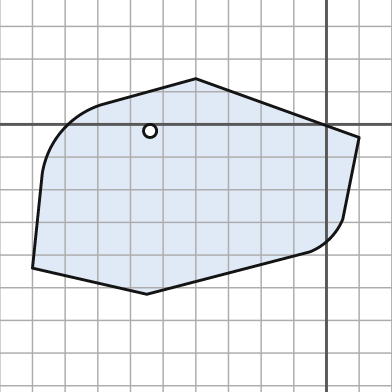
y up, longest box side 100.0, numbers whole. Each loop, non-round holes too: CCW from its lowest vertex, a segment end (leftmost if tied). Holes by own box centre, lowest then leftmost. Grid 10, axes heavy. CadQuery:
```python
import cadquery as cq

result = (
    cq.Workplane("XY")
    .moveTo(-55.0, -52.0)
    .lineTo(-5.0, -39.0)
    .threePointArc((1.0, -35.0), (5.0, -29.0))
    .lineTo(10.0, -4.0)
    .lineTo(-40.0, 14.0)
    .lineTo(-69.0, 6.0)
    .threePointArc((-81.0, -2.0), (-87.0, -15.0))
    .lineTo(-90.0, -44.0)
    .close()
    .moveTo(-54.0, -2.0)
    .circle(2.0)
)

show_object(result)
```